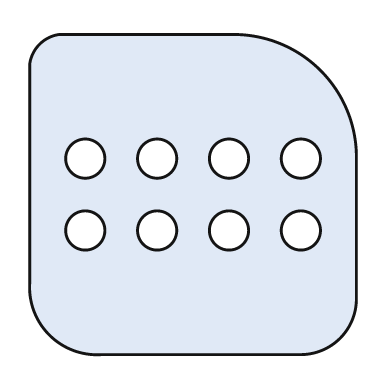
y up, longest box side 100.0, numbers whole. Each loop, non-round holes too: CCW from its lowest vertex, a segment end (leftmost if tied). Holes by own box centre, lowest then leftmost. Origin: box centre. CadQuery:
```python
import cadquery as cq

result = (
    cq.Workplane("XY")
    .moveTo(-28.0, -49.0)
    .lineTo(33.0, -49.0)
    .threePointArc((45.0, -44.0), (50.0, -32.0))
    .lineTo(50.0, 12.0)
    .threePointArc((39.0, 38.0), (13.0, 49.0))
    .lineTo(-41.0, 49.0)
    .threePointArc((-47.0, 46.0), (-50.0, 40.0))
    .lineTo(-50.0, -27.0)
    .threePointArc((-44.0, -43.0), (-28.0, -49.0))
    .close()
    .moveTo(-33.0, -11.0)
    .circle(6.0)
    .moveTo(-11.0, -11.0)
    .circle(6.0)
    .moveTo(11.0, -11.0)
    .circle(6.0)
    .moveTo(33.0, -11.0)
    .circle(6.0)
    .moveTo(-33.0, 11.0)
    .circle(6.0)
    .moveTo(-11.0, 11.0)
    .circle(6.0)
    .moveTo(11.0, 11.0)
    .circle(6.0)
    .moveTo(33.0, 11.0)
    .circle(6.0)
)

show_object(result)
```